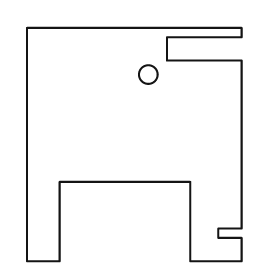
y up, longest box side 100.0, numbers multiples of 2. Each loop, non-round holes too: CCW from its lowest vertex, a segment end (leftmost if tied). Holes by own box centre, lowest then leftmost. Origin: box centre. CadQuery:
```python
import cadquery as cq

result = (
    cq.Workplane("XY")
    .moveTo(-46.0, -50.0)
    .lineTo(-32.0, -50.0)
    .lineTo(-32.0, -16.0)
    .lineTo(24.0, -16.0)
    .lineTo(24.0, -50.0)
    .lineTo(46.0, -50.0)
    .lineTo(46.0, -40.0)
    .lineTo(36.0, -40.0)
    .lineTo(36.0, -36.0)
    .lineTo(46.0, -36.0)
    .lineTo(46.0, 36.0)
    .lineTo(14.0, 36.0)
    .lineTo(14.0, 46.0)
    .lineTo(46.0, 46.0)
    .lineTo(46.0, 50.0)
    .lineTo(-46.0, 50.0)
    .close()
    .moveTo(6.0, 30.0)
    .circle(4.0)
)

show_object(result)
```